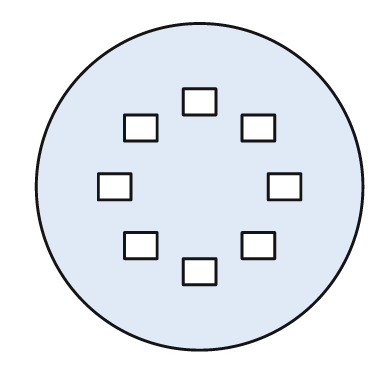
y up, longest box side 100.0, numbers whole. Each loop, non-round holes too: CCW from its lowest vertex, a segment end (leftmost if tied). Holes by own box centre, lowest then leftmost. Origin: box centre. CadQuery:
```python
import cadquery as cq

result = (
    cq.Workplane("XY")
    .moveTo(0.0, 0.0)
    .circle(50.0)
    .moveTo(-5.0, -30.0)
    .lineTo(5.0, -30.0)
    .lineTo(5.0, -22.0)
    .lineTo(-5.0, -22.0)
    .close()
    .moveTo(-23.0, -22.0)
    .lineTo(-13.0, -22.0)
    .lineTo(-13.0, -14.0)
    .lineTo(-23.0, -14.0)
    .close()
    .moveTo(13.0, -22.0)
    .lineTo(23.0, -22.0)
    .lineTo(23.0, -14.0)
    .lineTo(13.0, -14.0)
    .close()
    .moveTo(-31.0, -4.0)
    .lineTo(-21.0, -4.0)
    .lineTo(-21.0, 4.0)
    .lineTo(-31.0, 4.0)
    .close()
    .moveTo(21.0, -4.0)
    .lineTo(31.0, -4.0)
    .lineTo(31.0, 4.0)
    .lineTo(21.0, 4.0)
    .close()
    .moveTo(-23.0, 14.0)
    .lineTo(-13.0, 14.0)
    .lineTo(-13.0, 22.0)
    .lineTo(-23.0, 22.0)
    .close()
    .moveTo(13.0, 14.0)
    .lineTo(23.0, 14.0)
    .lineTo(23.0, 22.0)
    .lineTo(13.0, 22.0)
    .close()
    .moveTo(-5.0, 22.0)
    .lineTo(5.0, 22.0)
    .lineTo(5.0, 30.0)
    .lineTo(-5.0, 30.0)
    .close()
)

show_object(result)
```